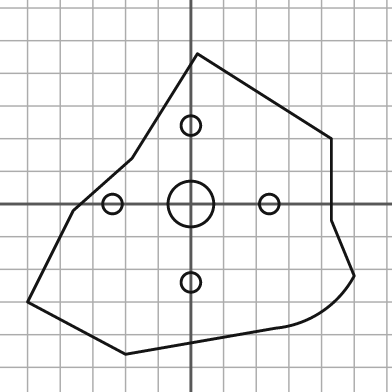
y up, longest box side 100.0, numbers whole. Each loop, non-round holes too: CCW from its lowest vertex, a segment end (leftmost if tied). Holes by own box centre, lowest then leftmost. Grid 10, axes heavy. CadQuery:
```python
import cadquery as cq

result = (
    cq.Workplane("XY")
    .moveTo(-20.0, -46.0)
    .lineTo(26.0, -38.0)
    .threePointArc((40.0, -33.0), (50.0, -22.0))
    .lineTo(43.0, -5.0)
    .lineTo(43.0, 20.0)
    .lineTo(2.0, 46.0)
    .lineTo(-18.0, 14.0)
    .lineTo(-36.0, -2.0)
    .lineTo(-50.0, -30.0)
    .close()
    .moveTo(0.0, -24.0)
    .circle(3.0)
    .moveTo(-24.0, 0.0)
    .circle(3.0)
    .moveTo(0.0, 0.0)
    .circle(7.0)
    .moveTo(24.0, 0.0)
    .circle(3.0)
    .moveTo(0.0, 24.0)
    .circle(3.0)
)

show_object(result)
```